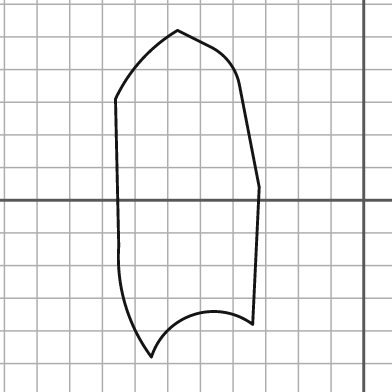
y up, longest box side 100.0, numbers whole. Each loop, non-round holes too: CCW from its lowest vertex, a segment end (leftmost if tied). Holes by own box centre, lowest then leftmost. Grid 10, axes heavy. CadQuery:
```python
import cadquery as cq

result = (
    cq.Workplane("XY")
    .moveTo(-65.0, -48.0)
    .threePointArc((-52.0, -35.0), (-34.0, -38.0))
    .lineTo(-32.0, 4.0)
    .lineTo(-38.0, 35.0)
    .threePointArc((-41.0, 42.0), (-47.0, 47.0))
    .lineTo(-57.0, 52.0)
    .threePointArc((-68.0, 43.0), (-76.0, 31.0))
    .lineTo(-75.0, -14.0)
    .threePointArc((-73.0, -32.0), (-65.0, -48.0))
    .close()
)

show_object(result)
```